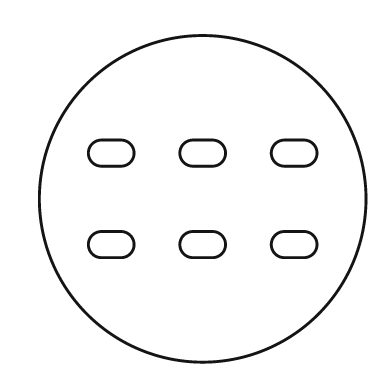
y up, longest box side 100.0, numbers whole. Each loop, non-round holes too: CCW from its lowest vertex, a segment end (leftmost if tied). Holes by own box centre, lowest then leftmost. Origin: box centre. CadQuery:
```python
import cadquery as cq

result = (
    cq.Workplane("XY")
    .moveTo(0.0, 0.0)
    .circle(50.0)
    .moveTo(-31.0, -18.0)
    .lineTo(-25.0, -18.0)
    .threePointArc((-21.0, -14.0), (-25.0, -10.0))
    .lineTo(-31.0, -10.0)
    .threePointArc((-35.0, -14.0), (-31.0, -18.0))
    .close()
    .moveTo(-3.0, -18.0)
    .lineTo(3.0, -18.0)
    .threePointArc((7.0, -14.0), (3.0, -10.0))
    .lineTo(-3.0, -10.0)
    .threePointArc((-7.0, -14.0), (-3.0, -18.0))
    .close()
    .moveTo(25.0, -18.0)
    .lineTo(31.0, -18.0)
    .threePointArc((35.0, -14.0), (31.0, -10.0))
    .lineTo(25.0, -10.0)
    .threePointArc((21.0, -14.0), (25.0, -18.0))
    .close()
    .moveTo(-31.0, 10.0)
    .lineTo(-25.0, 10.0)
    .threePointArc((-21.0, 14.0), (-25.0, 18.0))
    .lineTo(-31.0, 18.0)
    .threePointArc((-35.0, 14.0), (-31.0, 10.0))
    .close()
    .moveTo(-3.0, 10.0)
    .lineTo(3.0, 10.0)
    .threePointArc((7.0, 14.0), (3.0, 18.0))
    .lineTo(-3.0, 18.0)
    .threePointArc((-7.0, 14.0), (-3.0, 10.0))
    .close()
    .moveTo(25.0, 10.0)
    .lineTo(31.0, 10.0)
    .threePointArc((35.0, 14.0), (31.0, 18.0))
    .lineTo(25.0, 18.0)
    .threePointArc((21.0, 14.0), (25.0, 10.0))
    .close()
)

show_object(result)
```